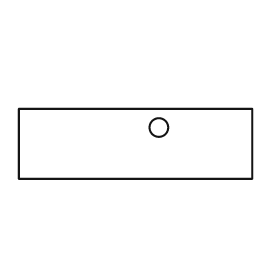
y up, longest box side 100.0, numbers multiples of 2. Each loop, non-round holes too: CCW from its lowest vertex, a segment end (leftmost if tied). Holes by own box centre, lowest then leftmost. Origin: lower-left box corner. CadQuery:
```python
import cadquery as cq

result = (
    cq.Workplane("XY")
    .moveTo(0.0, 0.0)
    .lineTo(100.0, 0.0)
    .lineTo(100.0, 30.0)
    .lineTo(0.0, 30.0)
    .close()
    .moveTo(60.0, 22.0)
    .circle(4.0)
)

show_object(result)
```